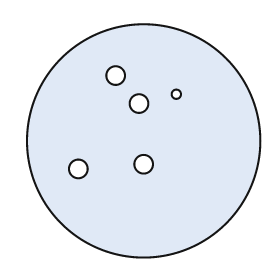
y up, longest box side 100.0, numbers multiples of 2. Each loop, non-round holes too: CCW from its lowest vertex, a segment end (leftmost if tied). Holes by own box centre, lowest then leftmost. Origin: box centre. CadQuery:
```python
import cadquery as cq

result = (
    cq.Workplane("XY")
    .moveTo(0.0, 0.0)
    .circle(50.0)
    .moveTo(-28.0, -12.0)
    .circle(4.0)
    .moveTo(0.0, -10.0)
    .circle(4.0)
    .moveTo(-2.0, 16.0)
    .circle(4.0)
    .moveTo(14.0, 20.0)
    .circle(2.0)
    .moveTo(-12.0, 28.0)
    .circle(4.0)
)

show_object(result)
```